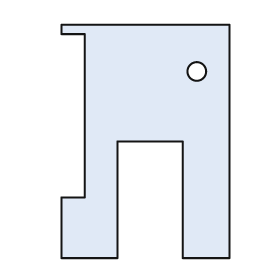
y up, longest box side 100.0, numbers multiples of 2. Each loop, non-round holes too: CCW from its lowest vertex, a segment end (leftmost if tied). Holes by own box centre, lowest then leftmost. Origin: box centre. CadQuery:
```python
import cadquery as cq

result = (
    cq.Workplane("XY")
    .moveTo(-36.0, -50.0)
    .lineTo(-12.0, -50.0)
    .lineTo(-12.0, 0.0)
    .lineTo(16.0, 0.0)
    .lineTo(16.0, -50.0)
    .lineTo(36.0, -50.0)
    .lineTo(36.0, 50.0)
    .lineTo(-36.0, 50.0)
    .lineTo(-36.0, 46.0)
    .lineTo(-26.0, 46.0)
    .lineTo(-26.0, -24.0)
    .lineTo(-36.0, -24.0)
    .close()
    .moveTo(22.0, 30.0)
    .circle(4.0)
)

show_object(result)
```